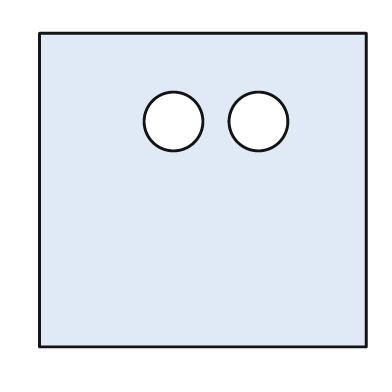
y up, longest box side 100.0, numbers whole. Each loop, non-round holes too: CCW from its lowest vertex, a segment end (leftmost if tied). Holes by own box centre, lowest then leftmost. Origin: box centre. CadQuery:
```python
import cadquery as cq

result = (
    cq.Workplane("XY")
    .moveTo(-50.0, -48.0)
    .lineTo(50.0, -48.0)
    .lineTo(50.0, 48.0)
    .lineTo(-50.0, 48.0)
    .close()
    .moveTo(-9.0, 21.0)
    .circle(9.0)
    .moveTo(17.0, 21.0)
    .circle(9.0)
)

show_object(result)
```